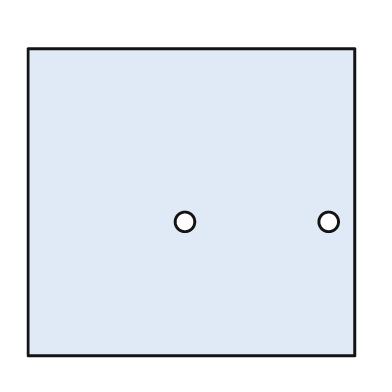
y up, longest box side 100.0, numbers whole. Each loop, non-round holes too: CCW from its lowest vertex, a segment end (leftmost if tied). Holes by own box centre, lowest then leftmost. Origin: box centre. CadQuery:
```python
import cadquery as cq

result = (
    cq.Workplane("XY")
    .moveTo(-50.0, -47.0)
    .lineTo(50.0, -47.0)
    .lineTo(50.0, 47.0)
    .lineTo(-50.0, 47.0)
    .close()
    .moveTo(-2.0, -6.0)
    .circle(3.0)
    .moveTo(42.0, -6.0)
    .circle(3.0)
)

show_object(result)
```